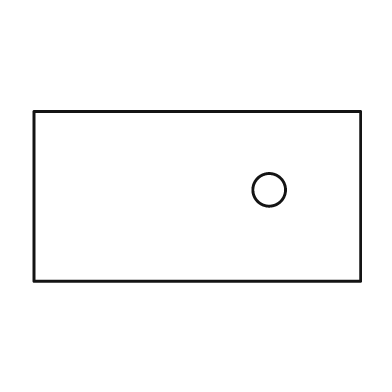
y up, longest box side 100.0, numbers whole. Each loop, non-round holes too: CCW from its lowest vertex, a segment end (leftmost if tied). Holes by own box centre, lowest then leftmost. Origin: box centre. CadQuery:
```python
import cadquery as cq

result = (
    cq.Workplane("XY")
    .moveTo(-50.0, -26.0)
    .lineTo(50.0, -26.0)
    .lineTo(50.0, 26.0)
    .lineTo(-50.0, 26.0)
    .close()
    .moveTo(22.0, 2.0)
    .circle(5.0)
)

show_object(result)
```